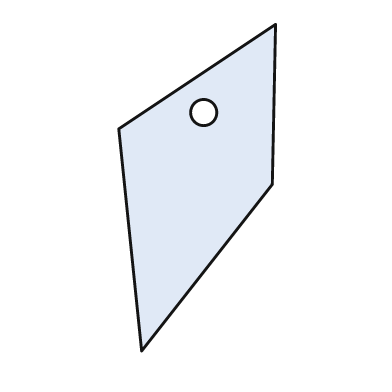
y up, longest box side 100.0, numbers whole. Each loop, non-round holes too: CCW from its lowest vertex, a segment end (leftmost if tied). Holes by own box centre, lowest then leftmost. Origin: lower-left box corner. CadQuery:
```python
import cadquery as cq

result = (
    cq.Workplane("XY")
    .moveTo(7.0, 0.0)
    .lineTo(47.0, 51.0)
    .lineTo(48.0, 100.0)
    .lineTo(0.0, 68.0)
    .close()
    .moveTo(26.0, 73.0)
    .circle(4.0)
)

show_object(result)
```